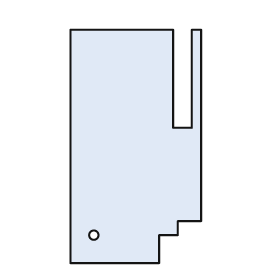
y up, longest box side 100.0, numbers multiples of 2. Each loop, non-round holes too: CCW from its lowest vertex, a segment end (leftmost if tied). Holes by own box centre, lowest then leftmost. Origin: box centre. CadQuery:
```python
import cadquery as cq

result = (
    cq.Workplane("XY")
    .moveTo(-28.0, -50.0)
    .lineTo(10.0, -50.0)
    .lineTo(10.0, -38.0)
    .lineTo(18.0, -38.0)
    .lineTo(18.0, -32.0)
    .lineTo(28.0, -32.0)
    .lineTo(28.0, 50.0)
    .lineTo(24.0, 50.0)
    .lineTo(24.0, 8.0)
    .lineTo(16.0, 8.0)
    .lineTo(16.0, 50.0)
    .lineTo(-28.0, 50.0)
    .close()
    .moveTo(-18.0, -38.0)
    .circle(2.0)
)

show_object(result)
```